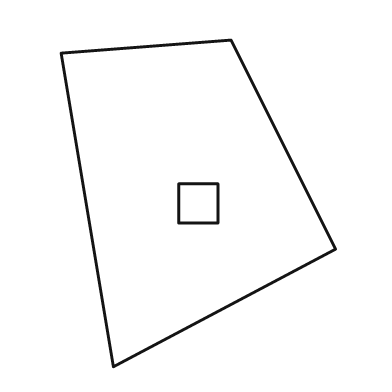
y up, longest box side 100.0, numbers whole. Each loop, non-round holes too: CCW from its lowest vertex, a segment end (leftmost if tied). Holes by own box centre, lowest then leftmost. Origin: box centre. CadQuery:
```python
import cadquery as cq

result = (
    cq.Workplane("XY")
    .moveTo(-26.0, -50.0)
    .lineTo(42.0, -14.0)
    .lineTo(10.0, 50.0)
    .lineTo(-42.0, 46.0)
    .close()
    .moveTo(-6.0, -6.0)
    .lineTo(6.0, -6.0)
    .lineTo(6.0, 6.0)
    .lineTo(-6.0, 6.0)
    .close()
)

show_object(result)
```